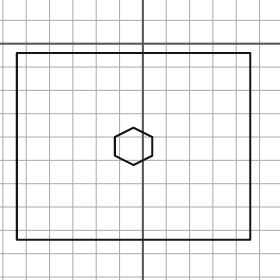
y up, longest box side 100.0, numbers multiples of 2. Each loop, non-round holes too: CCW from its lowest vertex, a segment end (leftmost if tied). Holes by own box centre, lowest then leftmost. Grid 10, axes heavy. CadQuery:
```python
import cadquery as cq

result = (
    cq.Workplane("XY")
    .moveTo(-54.0, -84.0)
    .lineTo(46.0, -84.0)
    .lineTo(46.0, -4.0)
    .lineTo(-54.0, -4.0)
    .close()
    .moveTo(-4.0, -52.0)
    .lineTo(4.0, -48.0)
    .lineTo(4.0, -40.0)
    .lineTo(-4.0, -36.0)
    .lineTo(-12.0, -40.0)
    .lineTo(-12.0, -48.0)
    .close()
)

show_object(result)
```